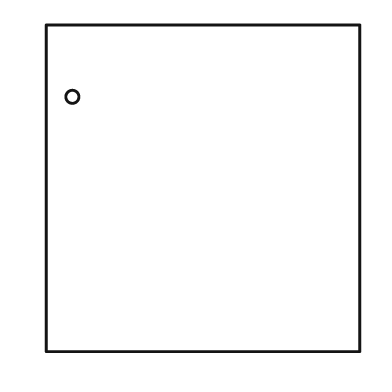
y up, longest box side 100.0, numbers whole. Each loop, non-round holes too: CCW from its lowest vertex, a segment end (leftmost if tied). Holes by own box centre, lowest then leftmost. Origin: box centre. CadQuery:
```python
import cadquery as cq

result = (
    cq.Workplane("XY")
    .moveTo(-48.0, -50.0)
    .lineTo(48.0, -50.0)
    .lineTo(48.0, 50.0)
    .lineTo(-48.0, 50.0)
    .close()
    .moveTo(-40.0, 28.0)
    .circle(2.0)
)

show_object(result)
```